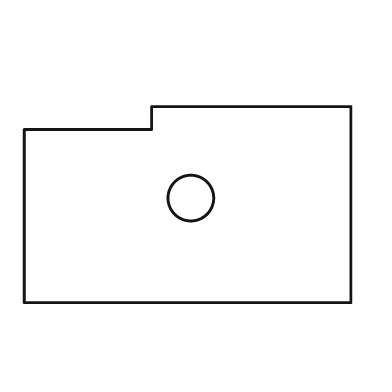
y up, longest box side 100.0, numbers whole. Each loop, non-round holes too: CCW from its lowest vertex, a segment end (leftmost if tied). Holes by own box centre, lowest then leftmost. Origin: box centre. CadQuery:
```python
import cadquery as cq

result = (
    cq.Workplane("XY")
    .moveTo(-50.0, -30.0)
    .lineTo(50.0, -30.0)
    .lineTo(50.0, 30.0)
    .lineTo(-11.0, 30.0)
    .lineTo(-11.0, 23.0)
    .lineTo(-50.0, 23.0)
    .close()
    .moveTo(1.0, 2.0)
    .circle(7.0)
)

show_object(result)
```